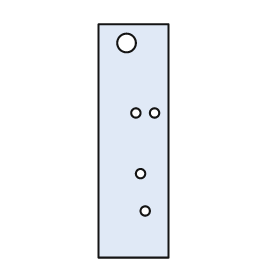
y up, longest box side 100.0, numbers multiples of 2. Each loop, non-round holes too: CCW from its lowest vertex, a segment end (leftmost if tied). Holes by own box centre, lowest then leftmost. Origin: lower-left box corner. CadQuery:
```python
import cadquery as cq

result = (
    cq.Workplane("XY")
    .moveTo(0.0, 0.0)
    .lineTo(30.0, 0.0)
    .lineTo(30.0, 100.0)
    .lineTo(0.0, 100.0)
    .close()
    .moveTo(20.0, 20.0)
    .circle(2.0)
    .moveTo(18.0, 36.0)
    .circle(2.0)
    .moveTo(16.0, 62.0)
    .circle(2.0)
    .moveTo(24.0, 62.0)
    .circle(2.0)
    .moveTo(12.0, 92.0)
    .circle(4.0)
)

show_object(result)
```